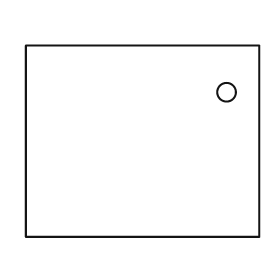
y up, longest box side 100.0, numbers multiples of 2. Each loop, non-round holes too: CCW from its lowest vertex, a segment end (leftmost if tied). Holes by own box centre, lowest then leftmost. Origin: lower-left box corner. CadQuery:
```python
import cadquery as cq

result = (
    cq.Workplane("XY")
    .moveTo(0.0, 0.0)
    .lineTo(100.0, 0.0)
    .lineTo(100.0, 82.0)
    .lineTo(0.0, 82.0)
    .close()
    .moveTo(86.0, 62.0)
    .circle(4.0)
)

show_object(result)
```